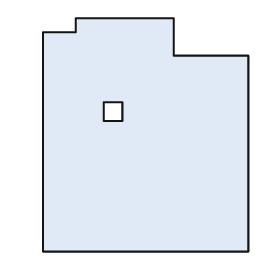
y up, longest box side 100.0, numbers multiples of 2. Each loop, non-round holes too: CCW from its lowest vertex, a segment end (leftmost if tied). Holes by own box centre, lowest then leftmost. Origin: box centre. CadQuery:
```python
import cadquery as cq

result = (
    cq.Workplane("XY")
    .moveTo(-44.0, -50.0)
    .lineTo(44.0, -50.0)
    .lineTo(44.0, 34.0)
    .lineTo(12.0, 34.0)
    .lineTo(12.0, 50.0)
    .lineTo(-30.0, 50.0)
    .lineTo(-30.0, 44.0)
    .lineTo(-44.0, 44.0)
    .close()
    .moveTo(-18.0, 6.0)
    .lineTo(-10.0, 6.0)
    .lineTo(-10.0, 14.0)
    .lineTo(-18.0, 14.0)
    .close()
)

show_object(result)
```